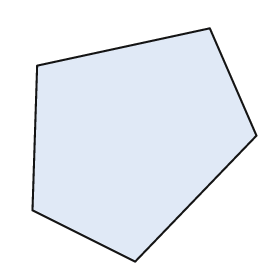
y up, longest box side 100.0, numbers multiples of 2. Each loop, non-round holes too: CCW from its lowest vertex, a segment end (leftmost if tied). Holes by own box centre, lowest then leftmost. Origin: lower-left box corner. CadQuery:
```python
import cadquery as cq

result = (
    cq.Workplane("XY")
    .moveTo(44.0, 0.0)
    .lineTo(96.0, 54.0)
    .lineTo(76.0, 100.0)
    .lineTo(2.0, 84.0)
    .lineTo(0.0, 22.0)
    .close()
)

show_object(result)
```